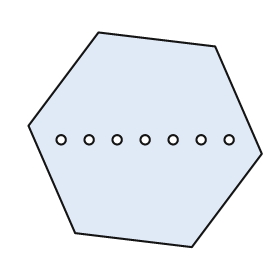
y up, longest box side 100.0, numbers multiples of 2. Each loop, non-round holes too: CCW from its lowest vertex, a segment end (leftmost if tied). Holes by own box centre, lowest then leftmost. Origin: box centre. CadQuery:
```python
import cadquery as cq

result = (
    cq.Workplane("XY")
    .moveTo(20.0, -46.0)
    .lineTo(50.0, -6.0)
    .lineTo(30.0, 40.0)
    .lineTo(-20.0, 46.0)
    .lineTo(-50.0, 6.0)
    .lineTo(-30.0, -40.0)
    .close()
    .moveTo(-36.0, 0.0)
    .circle(2.0)
    .moveTo(-24.0, 0.0)
    .circle(2.0)
    .moveTo(-12.0, 0.0)
    .circle(2.0)
    .moveTo(0.0, 0.0)
    .circle(2.0)
    .moveTo(12.0, 0.0)
    .circle(2.0)
    .moveTo(24.0, 0.0)
    .circle(2.0)
    .moveTo(36.0, 0.0)
    .circle(2.0)
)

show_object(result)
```